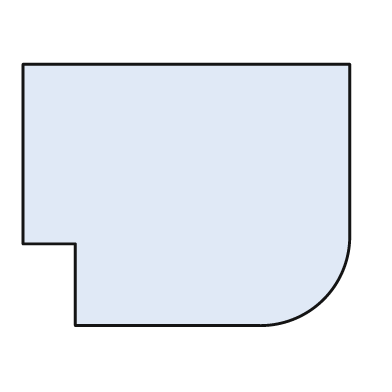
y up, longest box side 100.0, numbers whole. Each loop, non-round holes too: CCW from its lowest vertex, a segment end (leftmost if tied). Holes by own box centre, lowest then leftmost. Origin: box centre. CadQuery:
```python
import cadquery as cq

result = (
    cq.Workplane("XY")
    .moveTo(-34.0, -40.0)
    .lineTo(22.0, -40.0)
    .threePointArc((42.0, -32.0), (50.0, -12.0))
    .lineTo(50.0, 40.0)
    .lineTo(-50.0, 40.0)
    .lineTo(-50.0, -15.0)
    .lineTo(-34.0, -15.0)
    .close()
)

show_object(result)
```